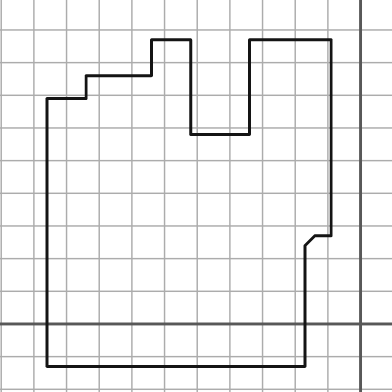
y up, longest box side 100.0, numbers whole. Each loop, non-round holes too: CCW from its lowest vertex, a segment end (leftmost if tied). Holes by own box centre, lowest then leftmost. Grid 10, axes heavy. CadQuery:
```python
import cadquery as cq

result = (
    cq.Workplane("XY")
    .moveTo(-96.0, -13.0)
    .lineTo(-17.0, -13.0)
    .lineTo(-17.0, 24.0)
    .lineTo(-14.0, 27.0)
    .lineTo(-9.0, 27.0)
    .lineTo(-9.0, 87.0)
    .lineTo(-34.0, 87.0)
    .lineTo(-34.0, 58.0)
    .lineTo(-52.0, 58.0)
    .lineTo(-52.0, 87.0)
    .lineTo(-64.0, 87.0)
    .lineTo(-64.0, 76.0)
    .lineTo(-84.0, 76.0)
    .lineTo(-84.0, 69.0)
    .lineTo(-96.0, 69.0)
    .close()
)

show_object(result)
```